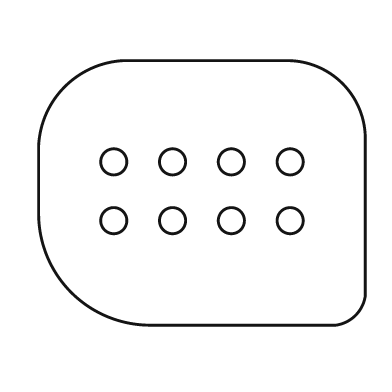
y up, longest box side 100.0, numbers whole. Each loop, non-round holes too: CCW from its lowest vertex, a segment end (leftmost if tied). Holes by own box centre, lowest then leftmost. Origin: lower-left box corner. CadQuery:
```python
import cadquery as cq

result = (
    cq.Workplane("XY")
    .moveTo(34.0, 0.0)
    .lineTo(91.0, 0.0)
    .threePointArc((97.0, 3.0), (100.0, 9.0))
    .lineTo(100.0, 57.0)
    .threePointArc((93.0, 74.0), (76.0, 81.0))
    .lineTo(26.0, 81.0)
    .threePointArc((8.0, 73.0), (0.0, 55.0))
    .lineTo(0.0, 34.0)
    .threePointArc((10.0, 10.0), (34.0, 0.0))
    .close()
    .moveTo(23.0, 32.0)
    .circle(4.0)
    .moveTo(41.0, 32.0)
    .circle(4.0)
    .moveTo(59.0, 32.0)
    .circle(4.0)
    .moveTo(77.0, 32.0)
    .circle(4.0)
    .moveTo(23.0, 50.0)
    .circle(4.0)
    .moveTo(41.0, 50.0)
    .circle(4.0)
    .moveTo(59.0, 50.0)
    .circle(4.0)
    .moveTo(77.0, 50.0)
    .circle(4.0)
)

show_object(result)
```